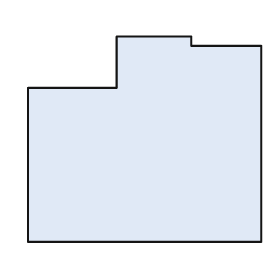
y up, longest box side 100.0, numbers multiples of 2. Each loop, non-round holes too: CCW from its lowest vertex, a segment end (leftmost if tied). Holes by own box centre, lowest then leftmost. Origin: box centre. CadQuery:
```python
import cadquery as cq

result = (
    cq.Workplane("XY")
    .moveTo(-50.0, -44.0)
    .lineTo(50.0, -44.0)
    .lineTo(50.0, 40.0)
    .lineTo(20.0, 40.0)
    .lineTo(20.0, 44.0)
    .lineTo(-12.0, 44.0)
    .lineTo(-12.0, 22.0)
    .lineTo(-50.0, 22.0)
    .close()
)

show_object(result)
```